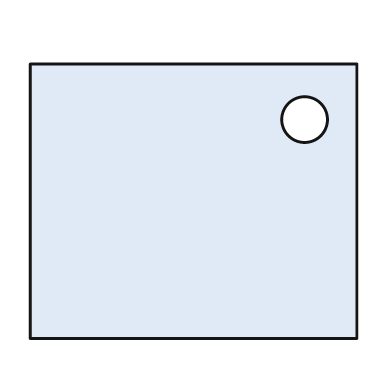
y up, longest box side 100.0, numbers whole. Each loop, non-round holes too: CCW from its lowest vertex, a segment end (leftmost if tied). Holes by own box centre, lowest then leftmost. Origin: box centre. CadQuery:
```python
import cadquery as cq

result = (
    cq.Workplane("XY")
    .moveTo(-50.0, -42.0)
    .lineTo(50.0, -42.0)
    .lineTo(50.0, 42.0)
    .lineTo(-50.0, 42.0)
    .close()
    .moveTo(34.0, 25.0)
    .circle(7.0)
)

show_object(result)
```